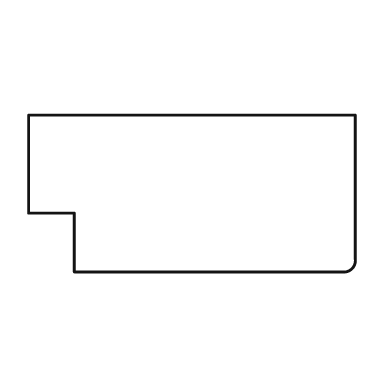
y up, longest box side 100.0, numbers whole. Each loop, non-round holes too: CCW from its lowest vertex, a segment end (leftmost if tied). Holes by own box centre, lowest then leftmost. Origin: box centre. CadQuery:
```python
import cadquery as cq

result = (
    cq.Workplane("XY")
    .moveTo(-36.0, -24.0)
    .lineTo(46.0, -24.0)
    .threePointArc((49.0, -23.0), (50.0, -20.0))
    .lineTo(50.0, 24.0)
    .lineTo(-50.0, 24.0)
    .lineTo(-50.0, -6.0)
    .lineTo(-36.0, -6.0)
    .close()
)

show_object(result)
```